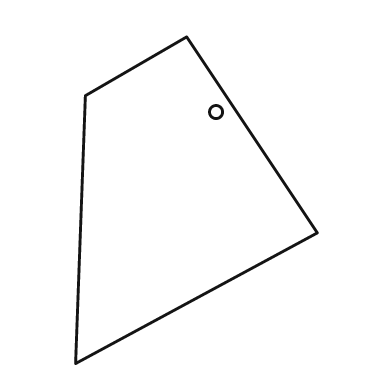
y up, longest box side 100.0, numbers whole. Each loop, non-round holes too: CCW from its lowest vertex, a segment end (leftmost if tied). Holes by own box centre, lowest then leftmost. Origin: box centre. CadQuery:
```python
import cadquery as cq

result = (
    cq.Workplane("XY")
    .moveTo(-37.0, -50.0)
    .lineTo(37.0, -10.0)
    .lineTo(-3.0, 50.0)
    .lineTo(-34.0, 32.0)
    .close()
    .moveTo(6.0, 27.0)
    .circle(2.0)
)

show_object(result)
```